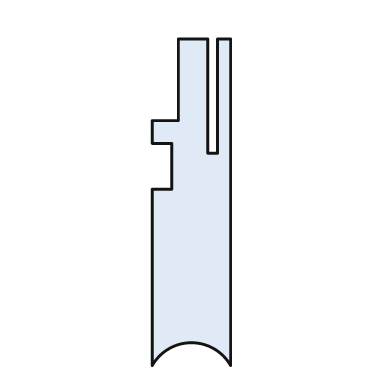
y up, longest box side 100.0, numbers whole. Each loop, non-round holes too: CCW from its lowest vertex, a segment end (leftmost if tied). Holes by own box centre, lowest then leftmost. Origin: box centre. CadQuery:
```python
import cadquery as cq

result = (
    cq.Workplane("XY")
    .moveTo(-12.0, -50.0)
    .threePointArc((0.0, -43.0), (12.0, -50.0))
    .lineTo(12.0, 50.0)
    .lineTo(8.0, 50.0)
    .lineTo(8.0, 15.0)
    .lineTo(5.0, 15.0)
    .lineTo(5.0, 50.0)
    .lineTo(-4.0, 50.0)
    .lineTo(-4.0, 25.0)
    .lineTo(-12.0, 25.0)
    .lineTo(-12.0, 18.0)
    .lineTo(-6.0, 18.0)
    .lineTo(-6.0, 4.0)
    .lineTo(-12.0, 4.0)
    .close()
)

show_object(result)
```